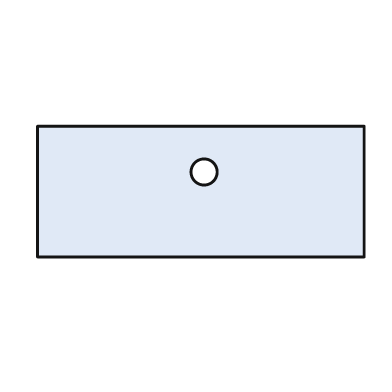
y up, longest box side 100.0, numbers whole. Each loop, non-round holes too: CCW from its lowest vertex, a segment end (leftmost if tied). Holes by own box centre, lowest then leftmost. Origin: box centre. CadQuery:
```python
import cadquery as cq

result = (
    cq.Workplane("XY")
    .moveTo(-50.0, -20.0)
    .lineTo(50.0, -20.0)
    .lineTo(50.0, 20.0)
    .lineTo(-50.0, 20.0)
    .close()
    .moveTo(1.0, 6.0)
    .circle(4.0)
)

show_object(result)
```